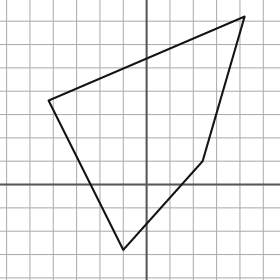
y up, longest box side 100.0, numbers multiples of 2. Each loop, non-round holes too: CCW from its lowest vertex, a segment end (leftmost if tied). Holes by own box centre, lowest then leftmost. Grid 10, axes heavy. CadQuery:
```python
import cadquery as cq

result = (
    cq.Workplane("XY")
    .moveTo(-10.0, -28.0)
    .lineTo(24.0, 10.0)
    .lineTo(42.0, 72.0)
    .lineTo(-42.0, 36.0)
    .close()
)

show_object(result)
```